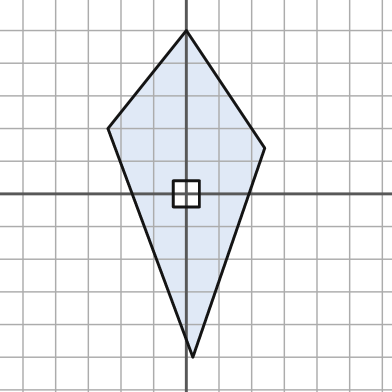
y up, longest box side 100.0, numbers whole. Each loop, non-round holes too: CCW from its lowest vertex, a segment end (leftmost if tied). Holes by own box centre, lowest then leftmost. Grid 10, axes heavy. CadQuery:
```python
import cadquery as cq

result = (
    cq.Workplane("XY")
    .moveTo(2.0, -50.0)
    .lineTo(24.0, 14.0)
    .lineTo(0.0, 50.0)
    .lineTo(-24.0, 20.0)
    .close()
    .moveTo(-4.0, -4.0)
    .lineTo(4.0, -4.0)
    .lineTo(4.0, 4.0)
    .lineTo(-4.0, 4.0)
    .close()
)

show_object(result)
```